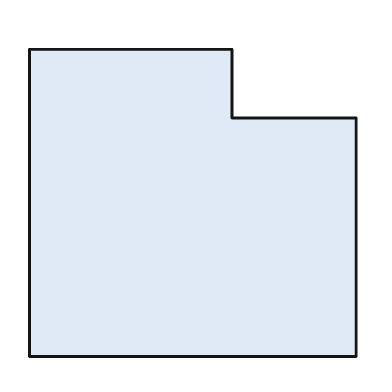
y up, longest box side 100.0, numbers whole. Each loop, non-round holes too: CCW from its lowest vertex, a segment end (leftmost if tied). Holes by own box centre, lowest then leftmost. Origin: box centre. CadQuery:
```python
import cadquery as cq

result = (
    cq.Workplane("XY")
    .moveTo(-50.0, -47.0)
    .lineTo(50.0, -47.0)
    .lineTo(50.0, 26.0)
    .lineTo(12.0, 26.0)
    .lineTo(12.0, 47.0)
    .lineTo(-50.0, 47.0)
    .close()
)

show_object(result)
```